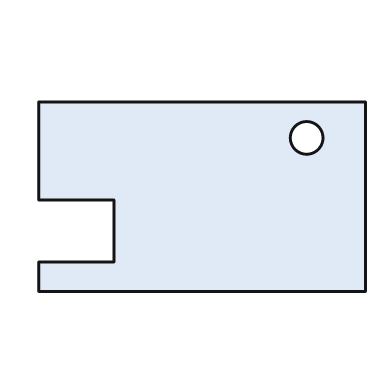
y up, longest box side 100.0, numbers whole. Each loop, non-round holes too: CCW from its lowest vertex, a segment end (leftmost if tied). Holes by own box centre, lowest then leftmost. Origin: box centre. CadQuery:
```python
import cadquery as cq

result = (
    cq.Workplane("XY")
    .moveTo(-50.0, -29.0)
    .lineTo(50.0, -29.0)
    .lineTo(50.0, 29.0)
    .lineTo(-50.0, 29.0)
    .lineTo(-50.0, -1.0)
    .lineTo(-27.0, -1.0)
    .lineTo(-27.0, -20.0)
    .lineTo(-50.0, -20.0)
    .close()
    .moveTo(32.0, 18.0)
    .circle(5.0)
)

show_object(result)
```